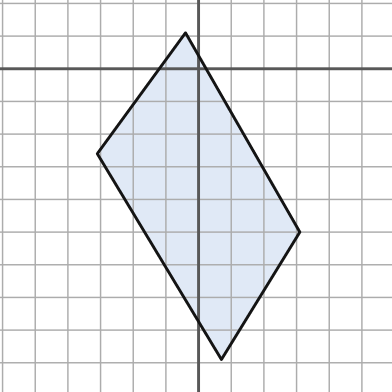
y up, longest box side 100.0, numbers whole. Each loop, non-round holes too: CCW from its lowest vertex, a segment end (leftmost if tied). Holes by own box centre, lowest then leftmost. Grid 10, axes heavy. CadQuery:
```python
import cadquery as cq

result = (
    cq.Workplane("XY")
    .moveTo(7.0, -89.0)
    .lineTo(31.0, -50.0)
    .lineTo(-4.0, 11.0)
    .lineTo(-31.0, -26.0)
    .close()
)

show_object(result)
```